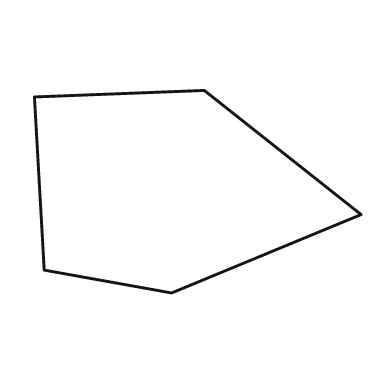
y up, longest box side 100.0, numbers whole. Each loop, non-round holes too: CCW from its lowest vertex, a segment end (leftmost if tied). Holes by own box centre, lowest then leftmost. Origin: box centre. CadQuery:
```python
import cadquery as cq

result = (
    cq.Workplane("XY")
    .moveTo(-8.0, -31.0)
    .lineTo(50.0, -7.0)
    .lineTo(2.0, 31.0)
    .lineTo(-50.0, 29.0)
    .lineTo(-47.0, -24.0)
    .close()
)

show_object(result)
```